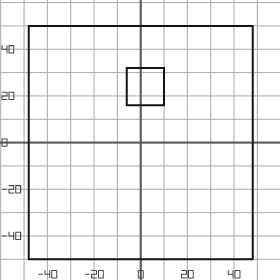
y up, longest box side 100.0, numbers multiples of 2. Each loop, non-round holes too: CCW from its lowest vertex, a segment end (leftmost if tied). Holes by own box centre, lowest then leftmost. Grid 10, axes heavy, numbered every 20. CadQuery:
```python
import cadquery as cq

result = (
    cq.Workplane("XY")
    .moveTo(-48.0, -50.0)
    .lineTo(48.0, -50.0)
    .lineTo(48.0, 50.0)
    .lineTo(-48.0, 50.0)
    .close()
    .moveTo(-6.0, 16.0)
    .lineTo(10.0, 16.0)
    .lineTo(10.0, 32.0)
    .lineTo(-6.0, 32.0)
    .close()
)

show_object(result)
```